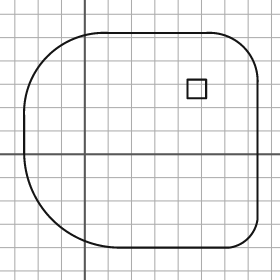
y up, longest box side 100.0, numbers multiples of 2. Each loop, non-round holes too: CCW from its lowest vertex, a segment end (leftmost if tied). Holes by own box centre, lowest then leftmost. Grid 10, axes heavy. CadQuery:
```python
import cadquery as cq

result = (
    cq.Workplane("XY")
    .moveTo(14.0, -40.0)
    .lineTo(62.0, -40.0)
    .threePointArc((70.0, -36.0), (74.0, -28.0))
    .lineTo(74.0, 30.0)
    .threePointArc((68.0, 46.0), (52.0, 52.0))
    .lineTo(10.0, 52.0)
    .threePointArc((-16.0, 42.0), (-26.0, 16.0))
    .lineTo(-26.0, 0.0)
    .threePointArc((-14.0, -28.0), (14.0, -40.0))
    .close()
    .moveTo(44.0, 24.0)
    .lineTo(52.0, 24.0)
    .lineTo(52.0, 32.0)
    .lineTo(44.0, 32.0)
    .close()
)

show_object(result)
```